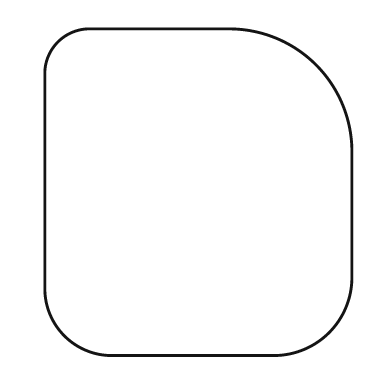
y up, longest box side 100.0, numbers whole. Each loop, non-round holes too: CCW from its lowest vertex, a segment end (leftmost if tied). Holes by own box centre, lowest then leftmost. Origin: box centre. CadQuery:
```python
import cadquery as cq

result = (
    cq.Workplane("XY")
    .moveTo(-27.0, -50.0)
    .lineTo(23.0, -50.0)
    .threePointArc((40.0, -43.0), (47.0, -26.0))
    .lineTo(47.0, 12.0)
    .threePointArc((36.0, 39.0), (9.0, 50.0))
    .lineTo(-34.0, 50.0)
    .threePointArc((-43.0, 46.0), (-47.0, 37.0))
    .lineTo(-47.0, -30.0)
    .threePointArc((-41.0, -44.0), (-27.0, -50.0))
    .close()
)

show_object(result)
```